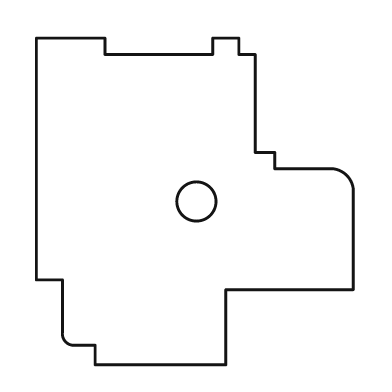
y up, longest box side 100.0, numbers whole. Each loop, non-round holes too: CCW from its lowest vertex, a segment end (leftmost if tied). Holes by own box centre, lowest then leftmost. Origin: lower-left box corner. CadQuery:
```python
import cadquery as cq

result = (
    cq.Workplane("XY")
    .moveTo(18.0, 0.0)
    .lineTo(58.0, 0.0)
    .lineTo(58.0, 23.0)
    .lineTo(97.0, 23.0)
    .lineTo(97.0, 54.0)
    .threePointArc((95.0, 58.0), (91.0, 60.0))
    .lineTo(73.0, 60.0)
    .lineTo(73.0, 65.0)
    .lineTo(67.0, 65.0)
    .lineTo(67.0, 95.0)
    .lineTo(62.0, 95.0)
    .lineTo(62.0, 100.0)
    .lineTo(54.0, 100.0)
    .lineTo(54.0, 95.0)
    .lineTo(21.0, 95.0)
    .lineTo(21.0, 100.0)
    .lineTo(0.0, 100.0)
    .lineTo(0.0, 26.0)
    .lineTo(8.0, 26.0)
    .lineTo(8.0, 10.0)
    .threePointArc((9.0, 7.0), (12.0, 6.0))
    .lineTo(18.0, 6.0)
    .close()
    .moveTo(49.0, 50.0)
    .circle(6.0)
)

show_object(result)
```